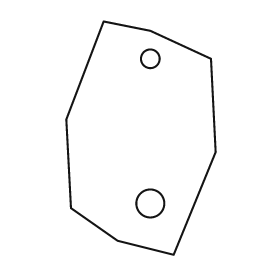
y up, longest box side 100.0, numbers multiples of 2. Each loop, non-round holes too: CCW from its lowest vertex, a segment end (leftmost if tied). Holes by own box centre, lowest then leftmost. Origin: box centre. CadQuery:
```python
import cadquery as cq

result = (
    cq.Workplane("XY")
    .moveTo(14.0, -50.0)
    .lineTo(32.0, -6.0)
    .lineTo(30.0, 34.0)
    .lineTo(4.0, 46.0)
    .lineTo(-16.0, 50.0)
    .lineTo(-32.0, 8.0)
    .lineTo(-30.0, -30.0)
    .lineTo(-10.0, -44.0)
    .close()
    .moveTo(4.0, -28.0)
    .circle(6.0)
    .moveTo(4.0, 34.0)
    .circle(4.0)
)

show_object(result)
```